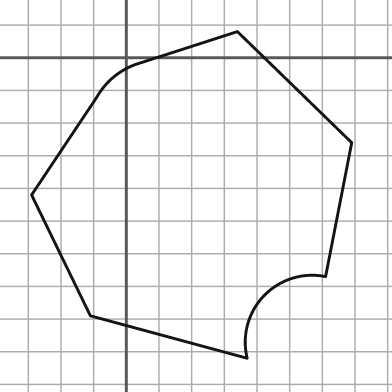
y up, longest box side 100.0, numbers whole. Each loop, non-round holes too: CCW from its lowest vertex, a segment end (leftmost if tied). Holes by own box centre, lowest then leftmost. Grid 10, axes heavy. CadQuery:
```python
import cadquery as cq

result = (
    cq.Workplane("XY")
    .moveTo(37.0, -92.0)
    .threePointArc((42.0, -73.0), (61.0, -67.0))
    .lineTo(69.0, -26.0)
    .lineTo(34.0, 8.0)
    .lineTo(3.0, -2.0)
    .threePointArc((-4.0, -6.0), (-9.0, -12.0))
    .lineTo(-29.0, -42.0)
    .lineTo(-11.0, -79.0)
    .close()
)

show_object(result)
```